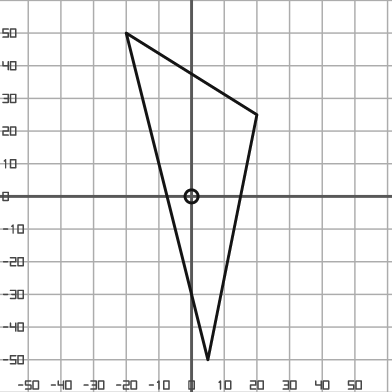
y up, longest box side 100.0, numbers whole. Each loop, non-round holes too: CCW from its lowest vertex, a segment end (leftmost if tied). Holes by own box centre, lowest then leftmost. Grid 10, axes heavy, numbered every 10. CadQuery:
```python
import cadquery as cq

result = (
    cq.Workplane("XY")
    .moveTo(5.0, -50.0)
    .lineTo(20.0, 25.0)
    .lineTo(-20.0, 50.0)
    .close()
    .moveTo(0.0, 0.0)
    .circle(2.0)
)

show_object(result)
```